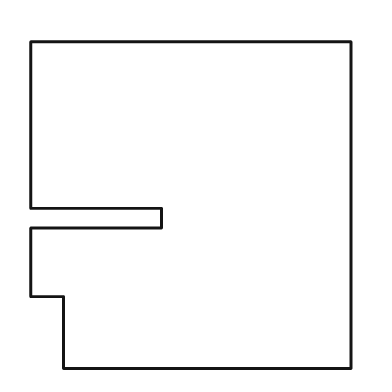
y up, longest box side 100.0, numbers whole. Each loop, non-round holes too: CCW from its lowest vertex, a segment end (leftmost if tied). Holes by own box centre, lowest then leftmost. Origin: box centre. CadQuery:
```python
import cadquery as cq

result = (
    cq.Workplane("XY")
    .moveTo(-39.0, -50.0)
    .lineTo(49.0, -50.0)
    .lineTo(49.0, 50.0)
    .lineTo(-49.0, 50.0)
    .lineTo(-49.0, -1.0)
    .lineTo(-9.0, -1.0)
    .lineTo(-9.0, -7.0)
    .lineTo(-49.0, -7.0)
    .lineTo(-49.0, -28.0)
    .lineTo(-39.0, -28.0)
    .close()
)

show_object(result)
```